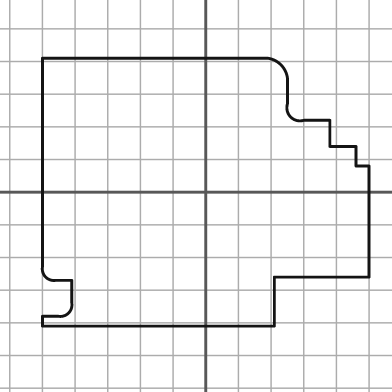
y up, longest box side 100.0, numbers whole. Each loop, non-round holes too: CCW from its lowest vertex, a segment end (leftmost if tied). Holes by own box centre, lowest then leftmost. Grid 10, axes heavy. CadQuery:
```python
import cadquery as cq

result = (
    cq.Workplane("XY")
    .moveTo(-50.0, -41.0)
    .lineTo(21.0, -41.0)
    .lineTo(21.0, -26.0)
    .lineTo(50.0, -26.0)
    .lineTo(50.0, 8.0)
    .lineTo(46.0, 8.0)
    .lineTo(46.0, 14.0)
    .lineTo(38.0, 14.0)
    .lineTo(38.0, 22.0)
    .lineTo(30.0, 22.0)
    .threePointArc((26.0, 23.0), (25.0, 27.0))
    .lineTo(25.0, 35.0)
    .threePointArc((23.0, 39.0), (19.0, 41.0))
    .lineTo(-50.0, 41.0)
    .lineTo(-50.0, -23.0)
    .threePointArc((-49.0, -26.0), (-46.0, -27.0))
    .lineTo(-41.0, -27.0)
    .lineTo(-41.0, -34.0)
    .threePointArc((-42.0, -37.0), (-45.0, -38.0))
    .lineTo(-50.0, -38.0)
    .close()
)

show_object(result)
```